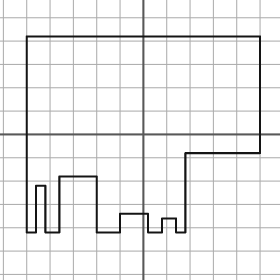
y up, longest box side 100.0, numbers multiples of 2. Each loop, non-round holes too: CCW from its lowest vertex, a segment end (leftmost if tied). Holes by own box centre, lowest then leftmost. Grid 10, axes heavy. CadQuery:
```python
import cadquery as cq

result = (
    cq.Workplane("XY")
    .moveTo(-50.0, -42.0)
    .lineTo(-46.0, -42.0)
    .lineTo(-46.0, -22.0)
    .lineTo(-42.0, -22.0)
    .lineTo(-42.0, -42.0)
    .lineTo(-36.0, -42.0)
    .lineTo(-36.0, -18.0)
    .lineTo(-20.0, -18.0)
    .lineTo(-20.0, -42.0)
    .lineTo(-10.0, -42.0)
    .lineTo(-10.0, -34.0)
    .lineTo(2.0, -34.0)
    .lineTo(2.0, -42.0)
    .lineTo(8.0, -42.0)
    .lineTo(8.0, -36.0)
    .lineTo(14.0, -36.0)
    .lineTo(14.0, -42.0)
    .lineTo(18.0, -42.0)
    .lineTo(18.0, -8.0)
    .lineTo(50.0, -8.0)
    .lineTo(50.0, 42.0)
    .lineTo(-50.0, 42.0)
    .close()
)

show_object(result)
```